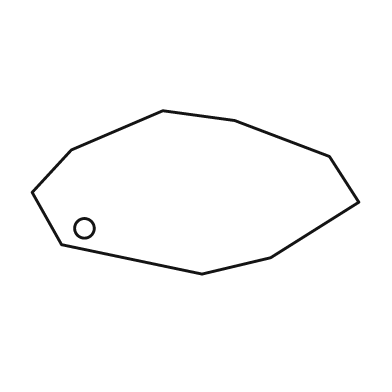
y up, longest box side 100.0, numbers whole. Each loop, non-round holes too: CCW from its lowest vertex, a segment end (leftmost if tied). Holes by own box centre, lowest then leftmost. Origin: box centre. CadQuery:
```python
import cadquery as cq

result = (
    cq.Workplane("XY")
    .moveTo(2.0, -25.0)
    .lineTo(23.0, -20.0)
    .lineTo(50.0, -3.0)
    .lineTo(41.0, 11.0)
    .lineTo(12.0, 22.0)
    .lineTo(-10.0, 25.0)
    .lineTo(-38.0, 13.0)
    .lineTo(-50.0, 0.0)
    .lineTo(-41.0, -16.0)
    .close()
    .moveTo(-34.0, -11.0)
    .circle(3.0)
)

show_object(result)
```